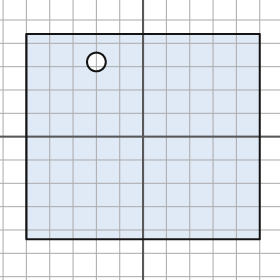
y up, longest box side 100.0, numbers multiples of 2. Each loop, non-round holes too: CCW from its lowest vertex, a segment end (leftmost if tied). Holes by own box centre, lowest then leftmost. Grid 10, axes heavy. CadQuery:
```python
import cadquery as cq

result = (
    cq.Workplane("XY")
    .moveTo(-50.0, -44.0)
    .lineTo(50.0, -44.0)
    .lineTo(50.0, 44.0)
    .lineTo(-50.0, 44.0)
    .close()
    .moveTo(-20.0, 32.0)
    .circle(4.0)
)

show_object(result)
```